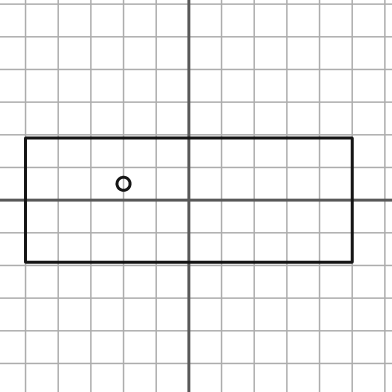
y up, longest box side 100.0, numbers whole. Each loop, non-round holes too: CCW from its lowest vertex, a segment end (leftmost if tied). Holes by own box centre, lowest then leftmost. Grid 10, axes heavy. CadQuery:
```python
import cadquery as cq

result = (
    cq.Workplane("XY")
    .moveTo(-50.0, -19.0)
    .lineTo(50.0, -19.0)
    .lineTo(50.0, 19.0)
    .lineTo(-50.0, 19.0)
    .close()
    .moveTo(-20.0, 5.0)
    .circle(2.0)
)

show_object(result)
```